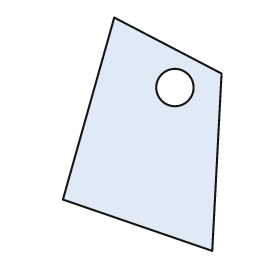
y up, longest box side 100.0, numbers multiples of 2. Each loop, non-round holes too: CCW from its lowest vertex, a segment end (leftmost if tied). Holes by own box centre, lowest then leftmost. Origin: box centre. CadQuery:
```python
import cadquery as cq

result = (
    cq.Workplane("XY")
    .moveTo(30.0, -50.0)
    .lineTo(34.0, 26.0)
    .lineTo(-12.0, 50.0)
    .lineTo(-34.0, -28.0)
    .close()
    .moveTo(14.0, 20.0)
    .circle(8.0)
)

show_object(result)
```